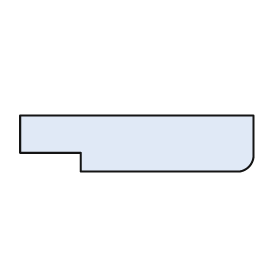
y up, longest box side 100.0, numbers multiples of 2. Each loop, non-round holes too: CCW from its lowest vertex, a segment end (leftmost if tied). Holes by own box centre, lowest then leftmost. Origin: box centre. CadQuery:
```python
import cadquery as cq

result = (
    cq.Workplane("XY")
    .moveTo(-24.0, -12.0)
    .lineTo(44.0, -12.0)
    .threePointArc((48.0, -10.0), (50.0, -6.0))
    .lineTo(50.0, 12.0)
    .lineTo(-50.0, 12.0)
    .lineTo(-50.0, -4.0)
    .lineTo(-24.0, -4.0)
    .close()
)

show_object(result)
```